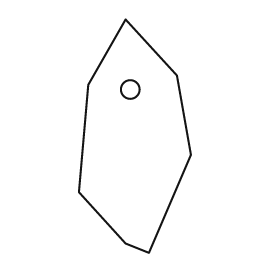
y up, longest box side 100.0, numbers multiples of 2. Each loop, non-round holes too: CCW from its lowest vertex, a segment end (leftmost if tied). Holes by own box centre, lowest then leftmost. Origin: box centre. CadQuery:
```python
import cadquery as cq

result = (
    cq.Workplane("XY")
    .moveTo(6.0, -50.0)
    .lineTo(24.0, -8.0)
    .lineTo(18.0, 26.0)
    .lineTo(-4.0, 50.0)
    .lineTo(-20.0, 22.0)
    .lineTo(-24.0, -24.0)
    .lineTo(-4.0, -46.0)
    .close()
    .moveTo(-2.0, 20.0)
    .circle(4.0)
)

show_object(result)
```